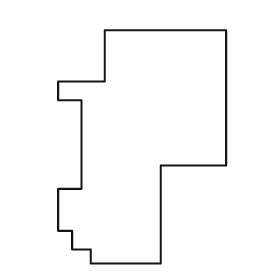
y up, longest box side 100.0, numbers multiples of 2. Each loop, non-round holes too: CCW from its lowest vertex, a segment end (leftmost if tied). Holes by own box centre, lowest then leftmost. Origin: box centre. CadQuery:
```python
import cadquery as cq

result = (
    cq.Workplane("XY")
    .moveTo(-22.0, -50.0)
    .lineTo(8.0, -50.0)
    .lineTo(8.0, -8.0)
    .lineTo(36.0, -8.0)
    .lineTo(36.0, 50.0)
    .lineTo(-16.0, 50.0)
    .lineTo(-16.0, 28.0)
    .lineTo(-36.0, 28.0)
    .lineTo(-36.0, 20.0)
    .lineTo(-26.0, 20.0)
    .lineTo(-26.0, -18.0)
    .lineTo(-36.0, -18.0)
    .lineTo(-36.0, -36.0)
    .lineTo(-30.0, -36.0)
    .lineTo(-30.0, -44.0)
    .lineTo(-22.0, -44.0)
    .close()
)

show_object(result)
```